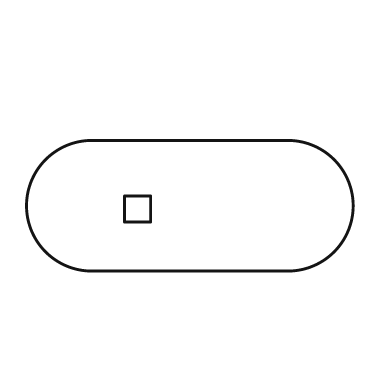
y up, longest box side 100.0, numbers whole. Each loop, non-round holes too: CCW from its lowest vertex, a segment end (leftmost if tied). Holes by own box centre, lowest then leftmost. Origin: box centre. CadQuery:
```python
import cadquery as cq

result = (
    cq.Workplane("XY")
    .moveTo(-30.0, -20.0)
    .lineTo(30.0, -20.0)
    .threePointArc((50.0, 0.0), (30.0, 20.0))
    .lineTo(-30.0, 20.0)
    .threePointArc((-50.0, 0.0), (-30.0, -20.0))
    .close()
    .moveTo(-20.0, -5.0)
    .lineTo(-12.0, -5.0)
    .lineTo(-12.0, 3.0)
    .lineTo(-20.0, 3.0)
    .close()
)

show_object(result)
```